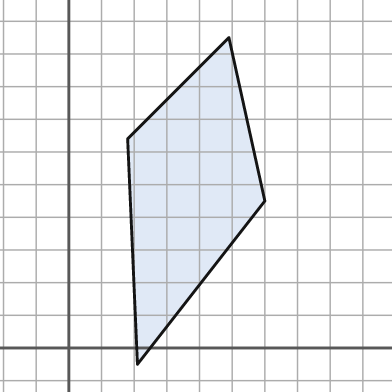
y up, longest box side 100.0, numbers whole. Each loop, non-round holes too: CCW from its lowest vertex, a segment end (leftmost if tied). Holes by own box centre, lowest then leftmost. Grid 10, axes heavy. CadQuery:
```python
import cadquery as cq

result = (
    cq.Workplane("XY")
    .moveTo(21.0, -5.0)
    .lineTo(60.0, 45.0)
    .lineTo(49.0, 95.0)
    .lineTo(18.0, 64.0)
    .close()
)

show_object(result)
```